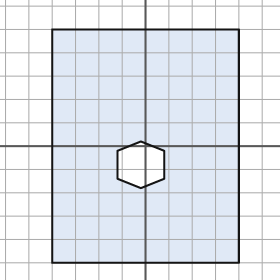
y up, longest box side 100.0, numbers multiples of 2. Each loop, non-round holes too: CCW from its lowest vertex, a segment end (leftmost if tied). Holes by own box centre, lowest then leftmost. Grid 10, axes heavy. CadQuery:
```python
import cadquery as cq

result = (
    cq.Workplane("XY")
    .moveTo(-40.0, -50.0)
    .lineTo(40.0, -50.0)
    .lineTo(40.0, 50.0)
    .lineTo(-40.0, 50.0)
    .close()
    .moveTo(-2.0, -18.0)
    .lineTo(8.0, -14.0)
    .lineTo(8.0, -2.0)
    .lineTo(-2.0, 2.0)
    .lineTo(-12.0, -2.0)
    .lineTo(-12.0, -14.0)
    .close()
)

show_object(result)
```